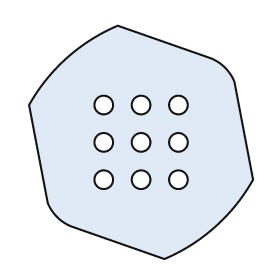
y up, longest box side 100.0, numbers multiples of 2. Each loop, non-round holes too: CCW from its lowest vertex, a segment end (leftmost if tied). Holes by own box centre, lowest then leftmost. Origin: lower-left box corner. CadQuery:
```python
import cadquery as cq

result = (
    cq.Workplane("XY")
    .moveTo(58.0, 0.0)
    .threePointArc((80.0, 14.0), (96.0, 34.0))
    .lineTo(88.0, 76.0)
    .threePointArc((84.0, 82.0), (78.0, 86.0))
    .lineTo(38.0, 100.0)
    .threePointArc((16.0, 86.0), (0.0, 66.0))
    .lineTo(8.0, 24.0)
    .threePointArc((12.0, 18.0), (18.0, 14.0))
    .close()
    .moveTo(32.0, 34.0)
    .circle(4.0)
    .moveTo(48.0, 34.0)
    .circle(4.0)
    .moveTo(64.0, 34.0)
    .circle(4.0)
    .moveTo(32.0, 50.0)
    .circle(4.0)
    .moveTo(48.0, 50.0)
    .circle(4.0)
    .moveTo(64.0, 50.0)
    .circle(4.0)
    .moveTo(32.0, 66.0)
    .circle(4.0)
    .moveTo(48.0, 66.0)
    .circle(4.0)
    .moveTo(64.0, 66.0)
    .circle(4.0)
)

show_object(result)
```